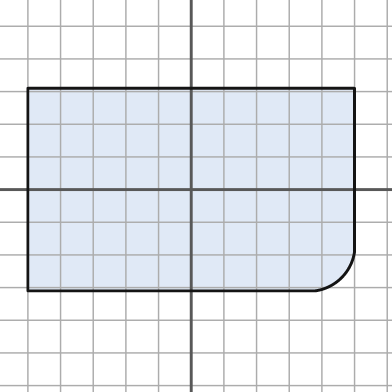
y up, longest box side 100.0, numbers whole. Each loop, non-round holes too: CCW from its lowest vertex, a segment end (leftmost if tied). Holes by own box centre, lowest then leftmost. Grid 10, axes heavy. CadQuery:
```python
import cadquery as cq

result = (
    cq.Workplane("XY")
    .moveTo(-50.0, -31.0)
    .lineTo(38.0, -31.0)
    .threePointArc((46.0, -27.0), (50.0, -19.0))
    .lineTo(50.0, 31.0)
    .lineTo(-50.0, 31.0)
    .close()
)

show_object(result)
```